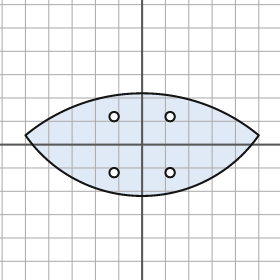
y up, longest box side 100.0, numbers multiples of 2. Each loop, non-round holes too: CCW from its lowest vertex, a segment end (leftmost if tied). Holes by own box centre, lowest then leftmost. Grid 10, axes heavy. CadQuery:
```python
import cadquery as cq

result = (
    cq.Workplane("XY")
    .moveTo(-50.0, 4.0)
    .threePointArc((0.0, -22.0), (50.0, 4.0))
    .threePointArc((0.0, 22.0), (-50.0, 4.0))
    .close()
    .moveTo(-12.0, -12.0)
    .circle(2.0)
    .moveTo(12.0, -12.0)
    .circle(2.0)
    .moveTo(-12.0, 12.0)
    .circle(2.0)
    .moveTo(12.0, 12.0)
    .circle(2.0)
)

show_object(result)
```